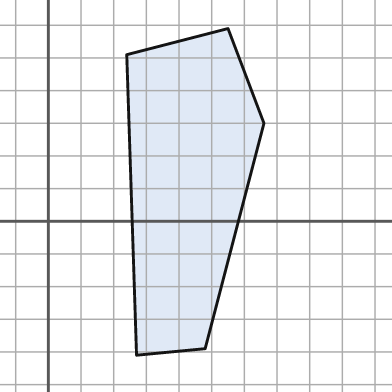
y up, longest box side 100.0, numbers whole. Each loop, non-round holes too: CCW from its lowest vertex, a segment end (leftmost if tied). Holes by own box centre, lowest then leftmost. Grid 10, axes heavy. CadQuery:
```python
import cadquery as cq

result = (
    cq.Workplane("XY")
    .moveTo(27.0, -41.0)
    .lineTo(48.0, -39.0)
    .lineTo(66.0, 30.0)
    .lineTo(55.0, 59.0)
    .lineTo(24.0, 51.0)
    .close()
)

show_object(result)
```